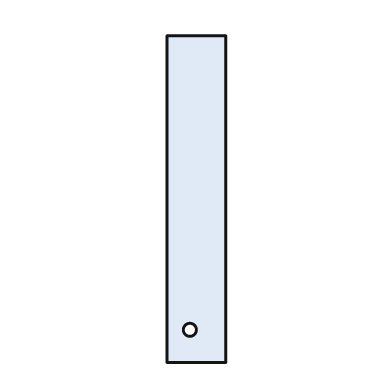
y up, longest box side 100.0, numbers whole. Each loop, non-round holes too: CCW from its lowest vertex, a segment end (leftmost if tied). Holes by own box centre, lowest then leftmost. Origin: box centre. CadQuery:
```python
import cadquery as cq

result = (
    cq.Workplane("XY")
    .moveTo(-9.0, -50.0)
    .lineTo(9.0, -50.0)
    .lineTo(9.0, 50.0)
    .lineTo(-9.0, 50.0)
    .close()
    .moveTo(-2.0, -40.0)
    .circle(2.0)
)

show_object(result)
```